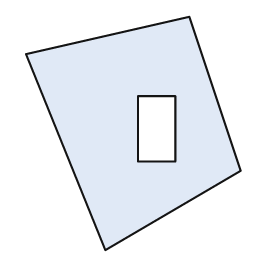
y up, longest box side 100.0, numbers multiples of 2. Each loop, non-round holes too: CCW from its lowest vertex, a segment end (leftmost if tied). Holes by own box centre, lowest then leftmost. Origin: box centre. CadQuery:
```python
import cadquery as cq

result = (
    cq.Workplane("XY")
    .moveTo(-12.0, -50.0)
    .lineTo(46.0, -16.0)
    .lineTo(24.0, 50.0)
    .lineTo(-46.0, 34.0)
    .close()
    .moveTo(2.0, -12.0)
    .lineTo(18.0, -12.0)
    .lineTo(18.0, 16.0)
    .lineTo(2.0, 16.0)
    .close()
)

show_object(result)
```